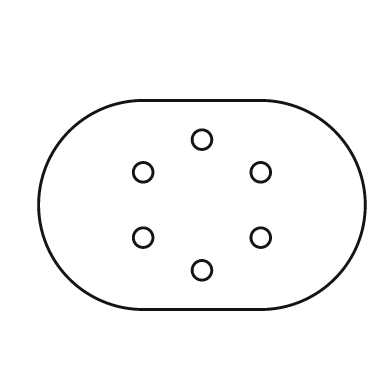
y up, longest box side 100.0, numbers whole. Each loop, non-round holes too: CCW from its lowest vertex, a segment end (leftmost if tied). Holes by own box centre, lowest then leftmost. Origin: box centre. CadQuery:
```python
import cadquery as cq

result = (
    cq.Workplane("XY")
    .moveTo(-18.0, -32.0)
    .lineTo(18.0, -32.0)
    .threePointArc((50.0, 0.0), (18.0, 32.0))
    .lineTo(-18.0, 32.0)
    .threePointArc((-50.0, 0.0), (-18.0, -32.0))
    .close()
    .moveTo(0.0, -20.0)
    .circle(3.0)
    .moveTo(-18.0, -10.0)
    .circle(3.0)
    .moveTo(18.0, -10.0)
    .circle(3.0)
    .moveTo(-18.0, 10.0)
    .circle(3.0)
    .moveTo(18.0, 10.0)
    .circle(3.0)
    .moveTo(0.0, 20.0)
    .circle(3.0)
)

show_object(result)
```